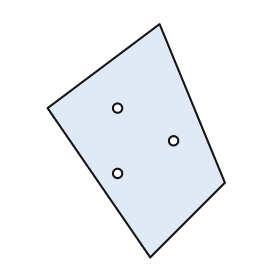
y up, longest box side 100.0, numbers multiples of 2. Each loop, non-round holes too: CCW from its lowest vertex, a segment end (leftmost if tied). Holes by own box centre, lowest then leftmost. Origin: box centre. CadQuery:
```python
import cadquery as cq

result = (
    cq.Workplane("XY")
    .moveTo(6.0, -50.0)
    .lineTo(38.0, -18.0)
    .lineTo(10.0, 50.0)
    .lineTo(-38.0, 14.0)
    .close()
    .moveTo(-8.0, -14.0)
    .circle(2.0)
    .moveTo(16.0, 0.0)
    .circle(2.0)
    .moveTo(-8.0, 14.0)
    .circle(2.0)
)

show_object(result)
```